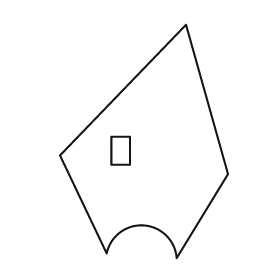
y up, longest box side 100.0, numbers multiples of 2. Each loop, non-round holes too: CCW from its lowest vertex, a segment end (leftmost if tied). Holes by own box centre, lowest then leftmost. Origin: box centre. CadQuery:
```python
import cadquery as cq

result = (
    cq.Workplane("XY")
    .moveTo(14.0, -50.0)
    .lineTo(36.0, -14.0)
    .lineTo(18.0, 50.0)
    .lineTo(-36.0, -6.0)
    .lineTo(-16.0, -48.0)
    .threePointArc((0.0, -36.0), (14.0, -50.0))
    .close()
    .moveTo(-14.0, -10.0)
    .lineTo(-6.0, -10.0)
    .lineTo(-6.0, 2.0)
    .lineTo(-14.0, 2.0)
    .close()
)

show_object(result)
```